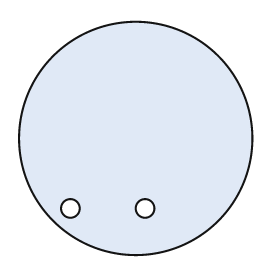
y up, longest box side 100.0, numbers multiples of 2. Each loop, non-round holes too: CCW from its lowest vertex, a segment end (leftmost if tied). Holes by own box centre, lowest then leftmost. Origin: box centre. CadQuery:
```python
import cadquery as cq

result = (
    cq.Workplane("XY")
    .moveTo(0.0, 0.0)
    .circle(50.0)
    .moveTo(-28.0, -30.0)
    .circle(4.0)
    .moveTo(4.0, -30.0)
    .circle(4.0)
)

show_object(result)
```